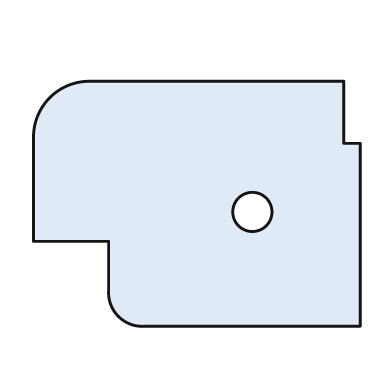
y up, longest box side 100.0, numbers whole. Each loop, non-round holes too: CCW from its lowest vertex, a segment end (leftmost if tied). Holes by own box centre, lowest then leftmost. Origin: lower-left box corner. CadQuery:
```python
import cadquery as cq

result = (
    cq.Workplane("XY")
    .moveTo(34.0, 0.0)
    .lineTo(100.0, 0.0)
    .lineTo(100.0, 56.0)
    .lineTo(95.0, 56.0)
    .lineTo(95.0, 75.0)
    .lineTo(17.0, 75.0)
    .threePointArc((5.0, 70.0), (0.0, 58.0))
    .lineTo(0.0, 26.0)
    .lineTo(23.0, 26.0)
    .lineTo(23.0, 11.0)
    .threePointArc((26.0, 3.0), (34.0, 0.0))
    .close()
    .moveTo(67.0, 35.0)
    .circle(6.0)
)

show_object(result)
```